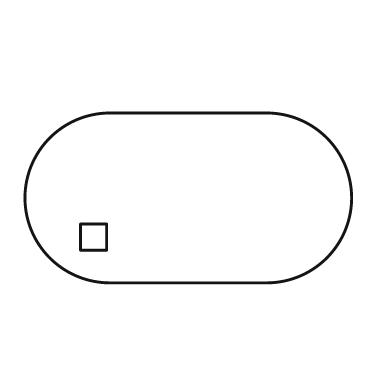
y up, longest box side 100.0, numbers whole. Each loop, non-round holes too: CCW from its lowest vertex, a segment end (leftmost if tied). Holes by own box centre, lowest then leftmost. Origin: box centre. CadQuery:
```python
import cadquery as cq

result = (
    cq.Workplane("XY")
    .moveTo(-24.0, -26.0)
    .lineTo(24.0, -26.0)
    .threePointArc((50.0, 0.0), (24.0, 26.0))
    .lineTo(-24.0, 26.0)
    .threePointArc((-50.0, 0.0), (-24.0, -26.0))
    .close()
    .moveTo(-33.0, -16.0)
    .lineTo(-25.0, -16.0)
    .lineTo(-25.0, -8.0)
    .lineTo(-33.0, -8.0)
    .close()
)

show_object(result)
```